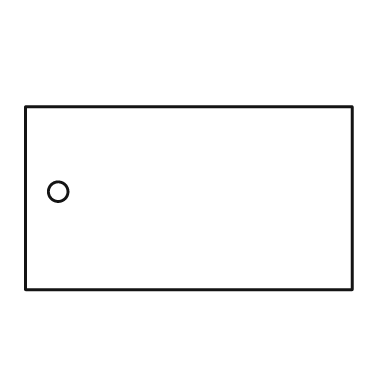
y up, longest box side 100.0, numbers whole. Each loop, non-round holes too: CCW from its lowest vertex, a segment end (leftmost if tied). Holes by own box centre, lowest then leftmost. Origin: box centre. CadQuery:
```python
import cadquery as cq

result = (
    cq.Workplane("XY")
    .moveTo(-50.0, -28.0)
    .lineTo(50.0, -28.0)
    .lineTo(50.0, 28.0)
    .lineTo(-50.0, 28.0)
    .close()
    .moveTo(-40.0, 2.0)
    .circle(3.0)
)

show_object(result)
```